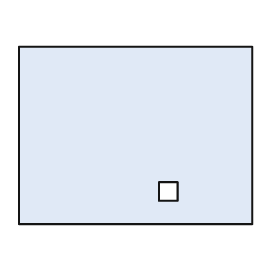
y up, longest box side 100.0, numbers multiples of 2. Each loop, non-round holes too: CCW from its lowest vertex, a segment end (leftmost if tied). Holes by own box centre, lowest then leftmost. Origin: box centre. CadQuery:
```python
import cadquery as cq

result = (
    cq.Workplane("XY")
    .moveTo(-50.0, -38.0)
    .lineTo(50.0, -38.0)
    .lineTo(50.0, 38.0)
    .lineTo(-50.0, 38.0)
    .close()
    .moveTo(10.0, -28.0)
    .lineTo(18.0, -28.0)
    .lineTo(18.0, -20.0)
    .lineTo(10.0, -20.0)
    .close()
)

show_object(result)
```